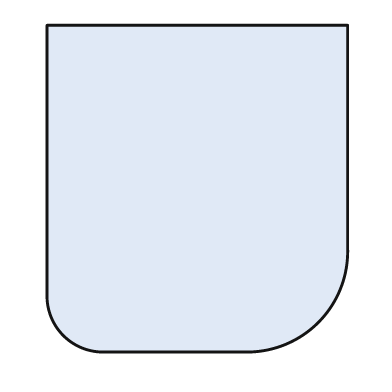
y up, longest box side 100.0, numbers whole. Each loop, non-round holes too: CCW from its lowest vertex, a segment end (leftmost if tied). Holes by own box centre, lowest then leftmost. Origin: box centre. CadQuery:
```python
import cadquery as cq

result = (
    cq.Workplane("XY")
    .moveTo(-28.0, -50.0)
    .lineTo(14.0, -50.0)
    .threePointArc((37.0, -41.0), (46.0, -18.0))
    .lineTo(46.0, 50.0)
    .lineTo(-46.0, 50.0)
    .lineTo(-46.0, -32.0)
    .threePointArc((-41.0, -45.0), (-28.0, -50.0))
    .close()
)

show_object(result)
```